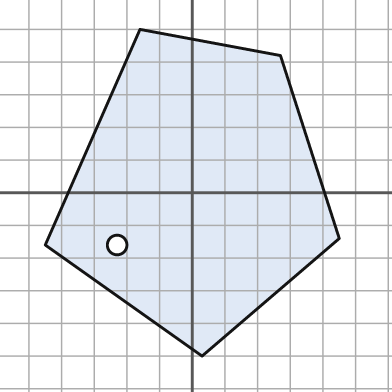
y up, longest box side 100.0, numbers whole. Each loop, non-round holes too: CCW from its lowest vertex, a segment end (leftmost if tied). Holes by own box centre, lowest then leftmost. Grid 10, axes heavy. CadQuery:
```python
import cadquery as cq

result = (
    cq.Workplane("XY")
    .moveTo(3.0, -50.0)
    .lineTo(45.0, -14.0)
    .lineTo(27.0, 42.0)
    .lineTo(-16.0, 50.0)
    .lineTo(-45.0, -16.0)
    .close()
    .moveTo(-23.0, -16.0)
    .circle(3.0)
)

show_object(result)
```